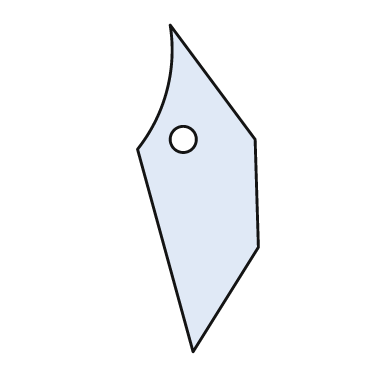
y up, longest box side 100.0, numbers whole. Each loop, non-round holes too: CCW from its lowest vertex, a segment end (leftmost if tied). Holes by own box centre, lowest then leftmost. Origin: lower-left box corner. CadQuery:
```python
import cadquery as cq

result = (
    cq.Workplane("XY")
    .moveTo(17.0, 0.0)
    .lineTo(37.0, 32.0)
    .lineTo(36.0, 65.0)
    .lineTo(10.0, 100.0)
    .threePointArc((9.0, 80.0), (0.0, 62.0))
    .close()
    .moveTo(14.0, 65.0)
    .circle(4.0)
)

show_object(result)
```